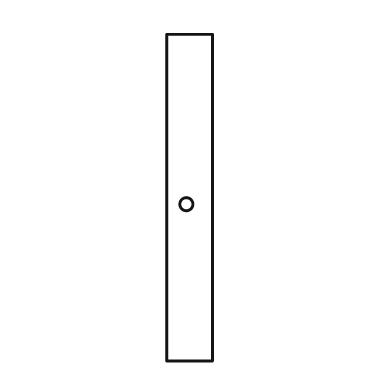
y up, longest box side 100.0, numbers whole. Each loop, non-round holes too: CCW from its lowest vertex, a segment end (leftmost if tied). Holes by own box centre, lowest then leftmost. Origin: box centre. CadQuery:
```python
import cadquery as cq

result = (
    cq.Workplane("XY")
    .moveTo(-7.0, -50.0)
    .lineTo(7.0, -50.0)
    .lineTo(7.0, 50.0)
    .lineTo(-7.0, 50.0)
    .close()
    .moveTo(-1.0, -2.0)
    .circle(2.0)
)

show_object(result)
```